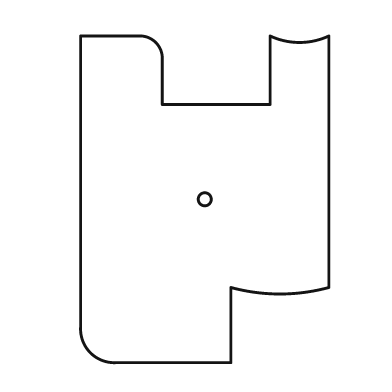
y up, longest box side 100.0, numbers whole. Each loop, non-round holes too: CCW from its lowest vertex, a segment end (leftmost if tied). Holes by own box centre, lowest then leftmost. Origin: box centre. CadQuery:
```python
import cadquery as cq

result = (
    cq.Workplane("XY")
    .moveTo(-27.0, -50.0)
    .lineTo(8.0, -50.0)
    .lineTo(8.0, -27.0)
    .threePointArc((23.0, -29.0), (38.0, -27.0))
    .lineTo(38.0, 50.0)
    .threePointArc((29.0, 48.0), (20.0, 50.0))
    .lineTo(20.0, 29.0)
    .lineTo(-13.0, 29.0)
    .lineTo(-13.0, 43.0)
    .threePointArc((-15.0, 48.0), (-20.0, 50.0))
    .lineTo(-38.0, 50.0)
    .lineTo(-38.0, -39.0)
    .threePointArc((-35.0, -47.0), (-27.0, -50.0))
    .close()
    .moveTo(0.0, 0.0)
    .circle(2.0)
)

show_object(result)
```